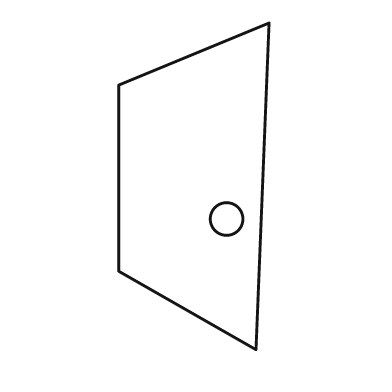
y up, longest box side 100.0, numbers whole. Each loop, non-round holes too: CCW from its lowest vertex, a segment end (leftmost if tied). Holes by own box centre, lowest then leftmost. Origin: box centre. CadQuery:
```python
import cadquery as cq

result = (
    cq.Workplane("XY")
    .moveTo(19.0, -50.0)
    .lineTo(23.0, 50.0)
    .lineTo(-23.0, 31.0)
    .lineTo(-23.0, -26.0)
    .close()
    .moveTo(10.0, -10.0)
    .circle(5.0)
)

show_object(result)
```